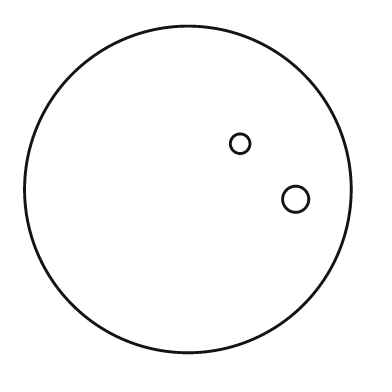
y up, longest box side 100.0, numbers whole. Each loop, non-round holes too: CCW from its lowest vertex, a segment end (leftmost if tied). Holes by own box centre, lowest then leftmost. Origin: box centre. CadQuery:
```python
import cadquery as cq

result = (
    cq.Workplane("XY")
    .moveTo(0.0, 0.0)
    .circle(50.0)
    .moveTo(33.0, -3.0)
    .circle(4.0)
    .moveTo(16.0, 14.0)
    .circle(3.0)
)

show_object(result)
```